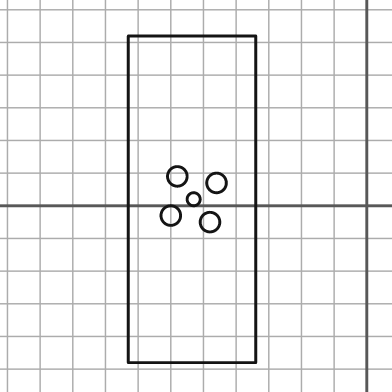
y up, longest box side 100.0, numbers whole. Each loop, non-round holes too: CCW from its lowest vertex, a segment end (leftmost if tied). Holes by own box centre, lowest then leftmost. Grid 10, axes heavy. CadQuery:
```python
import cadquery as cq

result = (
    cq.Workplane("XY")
    .moveTo(-73.0, -48.0)
    .lineTo(-34.0, -48.0)
    .lineTo(-34.0, 52.0)
    .lineTo(-73.0, 52.0)
    .close()
    .moveTo(-48.0, -5.0)
    .circle(3.0)
    .moveTo(-60.0, -3.0)
    .circle(3.0)
    .moveTo(-53.0, 2.0)
    .circle(2.0)
    .moveTo(-46.0, 7.0)
    .circle(3.0)
    .moveTo(-58.0, 9.0)
    .circle(3.0)
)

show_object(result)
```